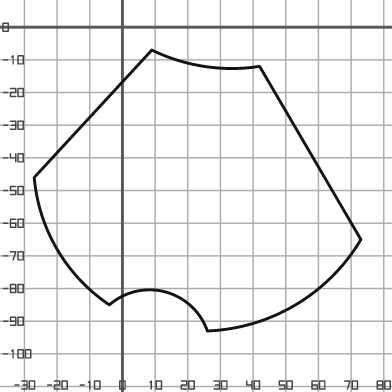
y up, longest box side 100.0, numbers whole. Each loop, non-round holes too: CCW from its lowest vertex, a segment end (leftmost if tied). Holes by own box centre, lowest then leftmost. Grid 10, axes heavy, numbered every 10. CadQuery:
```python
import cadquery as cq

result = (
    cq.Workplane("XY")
    .moveTo(26.0, -93.0)
    .threePointArc((53.0, -85.0), (73.0, -65.0))
    .lineTo(42.0, -12.0)
    .threePointArc((25.0, -12.0), (9.0, -7.0))
    .lineTo(-27.0, -46.0)
    .threePointArc((-20.0, -68.0), (-4.0, -85.0))
    .threePointArc((13.0, -81.0), (26.0, -93.0))
    .close()
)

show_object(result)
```